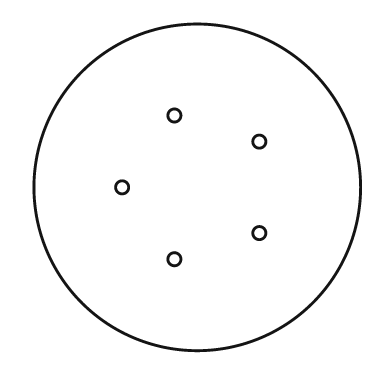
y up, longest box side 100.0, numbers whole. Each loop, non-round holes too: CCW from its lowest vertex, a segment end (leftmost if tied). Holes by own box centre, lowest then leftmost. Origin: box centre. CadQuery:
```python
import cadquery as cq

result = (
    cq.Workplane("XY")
    .moveTo(0.0, 0.0)
    .circle(50.0)
    .moveTo(-7.0, -22.0)
    .circle(2.0)
    .moveTo(19.0, -14.0)
    .circle(2.0)
    .moveTo(-23.0, 0.0)
    .circle(2.0)
    .moveTo(19.0, 14.0)
    .circle(2.0)
    .moveTo(-7.0, 22.0)
    .circle(2.0)
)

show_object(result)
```